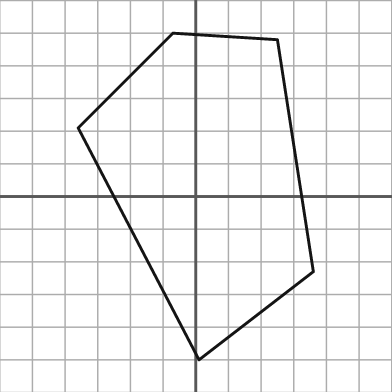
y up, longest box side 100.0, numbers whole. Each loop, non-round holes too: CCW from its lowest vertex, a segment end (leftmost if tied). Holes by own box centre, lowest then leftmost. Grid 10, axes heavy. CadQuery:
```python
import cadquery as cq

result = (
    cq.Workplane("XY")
    .moveTo(1.0, -50.0)
    .lineTo(36.0, -23.0)
    .lineTo(25.0, 48.0)
    .lineTo(-7.0, 50.0)
    .lineTo(-36.0, 21.0)
    .close()
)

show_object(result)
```